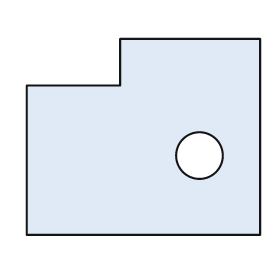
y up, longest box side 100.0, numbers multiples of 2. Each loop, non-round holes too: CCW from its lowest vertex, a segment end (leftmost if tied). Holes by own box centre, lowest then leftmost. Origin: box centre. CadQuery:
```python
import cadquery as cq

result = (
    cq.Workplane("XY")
    .moveTo(-50.0, -42.0)
    .lineTo(50.0, -42.0)
    .lineTo(50.0, 42.0)
    .lineTo(-10.0, 42.0)
    .lineTo(-10.0, 22.0)
    .lineTo(-50.0, 22.0)
    .close()
    .moveTo(24.0, -8.0)
    .circle(10.0)
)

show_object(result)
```